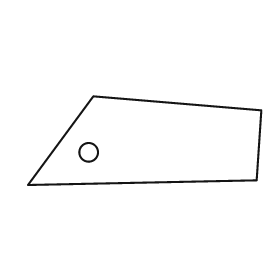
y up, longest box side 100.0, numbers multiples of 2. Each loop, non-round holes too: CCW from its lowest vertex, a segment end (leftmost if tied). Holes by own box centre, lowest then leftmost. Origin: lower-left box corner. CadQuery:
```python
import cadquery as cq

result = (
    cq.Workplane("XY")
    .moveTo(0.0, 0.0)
    .lineTo(98.0, 2.0)
    .lineTo(100.0, 32.0)
    .lineTo(28.0, 38.0)
    .close()
    .moveTo(26.0, 14.0)
    .circle(4.0)
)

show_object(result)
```